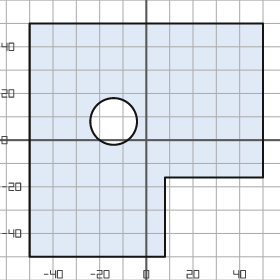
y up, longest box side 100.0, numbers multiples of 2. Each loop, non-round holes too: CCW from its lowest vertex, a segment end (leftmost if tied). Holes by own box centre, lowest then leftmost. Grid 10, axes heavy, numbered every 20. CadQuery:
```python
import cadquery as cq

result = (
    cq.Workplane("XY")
    .moveTo(-50.0, -50.0)
    .lineTo(8.0, -50.0)
    .lineTo(8.0, -16.0)
    .lineTo(50.0, -16.0)
    .lineTo(50.0, 50.0)
    .lineTo(-50.0, 50.0)
    .close()
    .moveTo(-14.0, 8.0)
    .circle(10.0)
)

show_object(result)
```